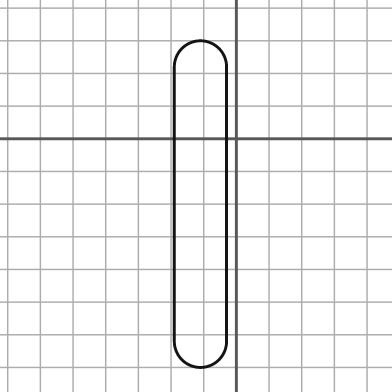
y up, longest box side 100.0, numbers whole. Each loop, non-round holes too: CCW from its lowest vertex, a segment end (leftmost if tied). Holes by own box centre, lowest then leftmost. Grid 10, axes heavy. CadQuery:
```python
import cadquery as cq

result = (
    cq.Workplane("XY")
    .moveTo(-19.0, -62.0)
    .threePointArc((-11.0, -70.0), (-3.0, -62.0))
    .lineTo(-3.0, 22.0)
    .threePointArc((-11.0, 30.0), (-19.0, 22.0))
    .close()
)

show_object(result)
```